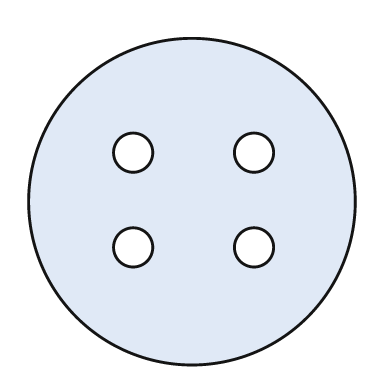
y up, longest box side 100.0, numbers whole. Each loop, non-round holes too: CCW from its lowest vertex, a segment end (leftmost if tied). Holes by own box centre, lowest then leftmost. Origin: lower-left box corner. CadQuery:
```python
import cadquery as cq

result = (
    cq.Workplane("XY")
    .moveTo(50.0, 50.0)
    .circle(50.0)
    .moveTo(32.0, 36.0)
    .circle(6.0)
    .moveTo(69.0, 36.0)
    .circle(6.0)
    .moveTo(32.0, 65.0)
    .circle(6.0)
    .moveTo(69.0, 65.0)
    .circle(6.0)
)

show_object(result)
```